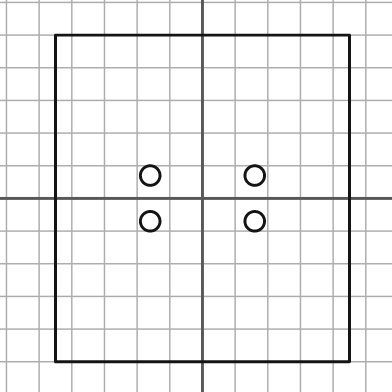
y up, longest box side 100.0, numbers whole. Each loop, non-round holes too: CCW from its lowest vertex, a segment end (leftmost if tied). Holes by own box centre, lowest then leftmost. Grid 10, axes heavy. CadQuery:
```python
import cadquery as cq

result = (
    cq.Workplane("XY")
    .moveTo(-45.0, -50.0)
    .lineTo(45.0, -50.0)
    .lineTo(45.0, 50.0)
    .lineTo(-45.0, 50.0)
    .close()
    .moveTo(-16.0, -7.0)
    .circle(3.0)
    .moveTo(16.0, -7.0)
    .circle(3.0)
    .moveTo(-16.0, 7.0)
    .circle(3.0)
    .moveTo(16.0, 7.0)
    .circle(3.0)
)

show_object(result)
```